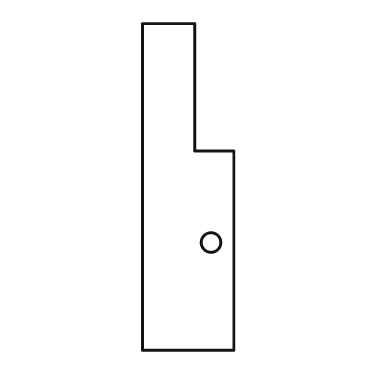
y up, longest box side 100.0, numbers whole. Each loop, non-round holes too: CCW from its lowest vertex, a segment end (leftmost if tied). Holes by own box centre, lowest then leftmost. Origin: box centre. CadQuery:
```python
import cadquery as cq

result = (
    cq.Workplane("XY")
    .moveTo(-14.0, -50.0)
    .lineTo(14.0, -50.0)
    .lineTo(14.0, 11.0)
    .lineTo(2.0, 11.0)
    .lineTo(2.0, 50.0)
    .lineTo(-14.0, 50.0)
    .close()
    .moveTo(7.0, -17.0)
    .circle(3.0)
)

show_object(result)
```